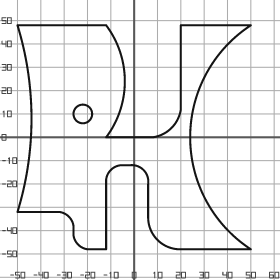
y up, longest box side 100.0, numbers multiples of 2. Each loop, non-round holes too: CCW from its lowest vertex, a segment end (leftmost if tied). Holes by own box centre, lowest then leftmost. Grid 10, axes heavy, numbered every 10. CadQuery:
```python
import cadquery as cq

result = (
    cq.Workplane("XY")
    .moveTo(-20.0, -48.0)
    .lineTo(-12.0, -48.0)
    .lineTo(-12.0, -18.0)
    .threePointArc((-10.0, -14.0), (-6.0, -12.0))
    .lineTo(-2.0, -12.0)
    .threePointArc((4.0, -14.0), (6.0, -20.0))
    .lineTo(6.0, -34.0)
    .threePointArc((10.0, -44.0), (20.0, -48.0))
    .lineTo(50.0, -48.0)
    .threePointArc((24.0, 0.0), (50.0, 48.0))
    .lineTo(20.0, 48.0)
    .lineTo(20.0, 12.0)
    .threePointArc((16.0, 4.0), (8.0, 0.0))
    .lineTo(-12.0, 0.0)
    .threePointArc((-4.0, 24.0), (-12.0, 48.0))
    .lineTo(-50.0, 48.0)
    .threePointArc((-44.0, 8.0), (-50.0, -32.0))
    .lineTo(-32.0, -32.0)
    .threePointArc((-28.0, -34.0), (-26.0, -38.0))
    .lineTo(-26.0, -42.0)
    .threePointArc((-24.0, -46.0), (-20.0, -48.0))
    .close()
    .moveTo(-22.0, 10.0)
    .circle(4.0)
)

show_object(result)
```